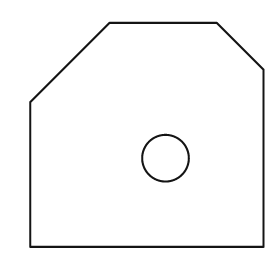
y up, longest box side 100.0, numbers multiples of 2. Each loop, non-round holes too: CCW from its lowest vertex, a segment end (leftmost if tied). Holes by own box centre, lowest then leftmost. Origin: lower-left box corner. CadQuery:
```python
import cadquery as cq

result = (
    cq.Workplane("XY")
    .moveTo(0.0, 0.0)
    .lineTo(100.0, 0.0)
    .lineTo(100.0, 76.0)
    .lineTo(80.0, 96.0)
    .lineTo(34.0, 96.0)
    .lineTo(0.0, 62.0)
    .close()
    .moveTo(58.0, 38.0)
    .circle(10.0)
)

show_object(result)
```